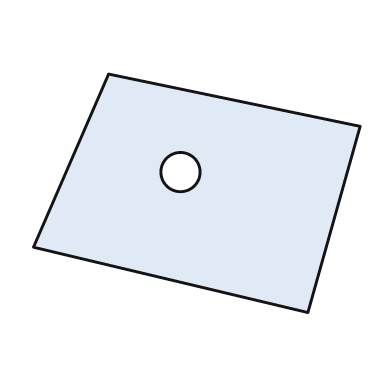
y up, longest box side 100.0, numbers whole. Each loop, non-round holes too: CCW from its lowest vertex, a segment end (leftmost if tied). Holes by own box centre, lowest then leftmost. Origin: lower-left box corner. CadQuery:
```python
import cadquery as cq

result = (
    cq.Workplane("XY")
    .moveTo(84.0, 0.0)
    .lineTo(100.0, 57.0)
    .lineTo(23.0, 73.0)
    .lineTo(0.0, 20.0)
    .close()
    .moveTo(45.0, 43.0)
    .circle(6.0)
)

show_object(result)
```